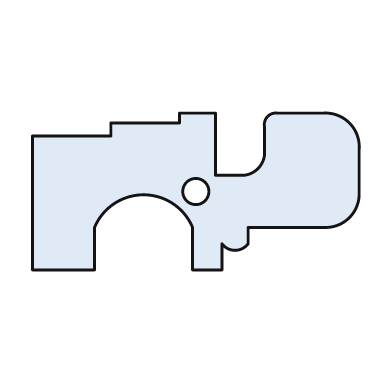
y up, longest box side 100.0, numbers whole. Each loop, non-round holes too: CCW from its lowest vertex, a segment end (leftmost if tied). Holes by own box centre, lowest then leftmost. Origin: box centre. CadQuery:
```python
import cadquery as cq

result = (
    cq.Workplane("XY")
    .moveTo(-50.0, -24.0)
    .lineTo(-31.0, -24.0)
    .lineTo(-31.0, -11.0)
    .threePointArc((-16.0, -1.0), (-1.0, -11.0))
    .lineTo(-1.0, -24.0)
    .lineTo(8.0, -24.0)
    .lineTo(8.0, -16.0)
    .threePointArc((12.0, -18.0), (16.0, -16.0))
    .lineTo(16.0, -11.0)
    .lineTo(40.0, -11.0)
    .threePointArc((47.0, -8.0), (50.0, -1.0))
    .lineTo(50.0, 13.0)
    .threePointArc((47.0, 21.0), (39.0, 24.0))
    .lineTo(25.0, 24.0)
    .threePointArc((22.0, 23.0), (21.0, 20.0))
    .lineTo(21.0, 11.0)
    .threePointArc((19.0, 7.0), (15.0, 5.0))
    .lineTo(6.0, 5.0)
    .lineTo(6.0, 24.0)
    .lineTo(-5.0, 24.0)
    .lineTo(-5.0, 21.0)
    .lineTo(-26.0, 21.0)
    .lineTo(-26.0, 17.0)
    .lineTo(-50.0, 17.0)
    .close()
    .moveTo(0.0, 0.0)
    .circle(4.0)
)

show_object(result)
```